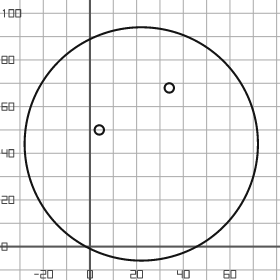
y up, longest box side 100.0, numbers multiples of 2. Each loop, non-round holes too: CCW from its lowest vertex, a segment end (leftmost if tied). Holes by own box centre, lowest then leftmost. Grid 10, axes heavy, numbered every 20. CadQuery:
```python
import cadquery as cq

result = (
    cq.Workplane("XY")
    .moveTo(22.0, 44.0)
    .circle(50.0)
    .moveTo(4.0, 50.0)
    .circle(2.0)
    .moveTo(34.0, 68.0)
    .circle(2.0)
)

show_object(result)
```